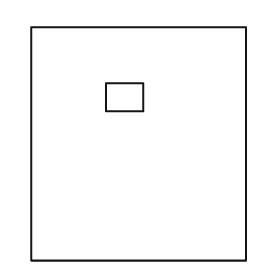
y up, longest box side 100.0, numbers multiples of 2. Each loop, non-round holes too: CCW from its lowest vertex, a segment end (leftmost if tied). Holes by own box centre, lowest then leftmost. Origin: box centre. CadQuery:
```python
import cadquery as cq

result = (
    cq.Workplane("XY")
    .moveTo(-46.0, -50.0)
    .lineTo(46.0, -50.0)
    .lineTo(46.0, 50.0)
    .lineTo(-46.0, 50.0)
    .close()
    .moveTo(-14.0, 14.0)
    .lineTo(2.0, 14.0)
    .lineTo(2.0, 26.0)
    .lineTo(-14.0, 26.0)
    .close()
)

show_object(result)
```